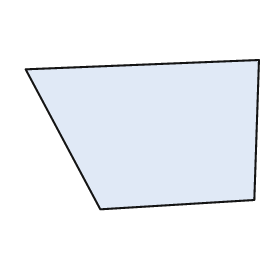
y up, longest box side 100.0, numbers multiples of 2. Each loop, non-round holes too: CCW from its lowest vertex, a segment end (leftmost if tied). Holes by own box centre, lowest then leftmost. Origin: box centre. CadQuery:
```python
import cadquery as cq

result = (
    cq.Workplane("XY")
    .moveTo(-18.0, -32.0)
    .lineTo(48.0, -28.0)
    .lineTo(50.0, 32.0)
    .lineTo(-50.0, 28.0)
    .close()
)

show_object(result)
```